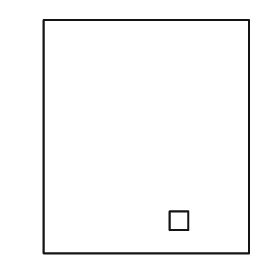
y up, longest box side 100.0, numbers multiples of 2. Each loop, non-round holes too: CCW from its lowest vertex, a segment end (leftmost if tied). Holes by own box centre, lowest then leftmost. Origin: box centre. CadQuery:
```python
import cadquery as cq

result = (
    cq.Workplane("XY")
    .moveTo(-44.0, -50.0)
    .lineTo(44.0, -50.0)
    .lineTo(44.0, 50.0)
    .lineTo(-44.0, 50.0)
    .close()
    .moveTo(10.0, -40.0)
    .lineTo(18.0, -40.0)
    .lineTo(18.0, -32.0)
    .lineTo(10.0, -32.0)
    .close()
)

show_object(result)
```